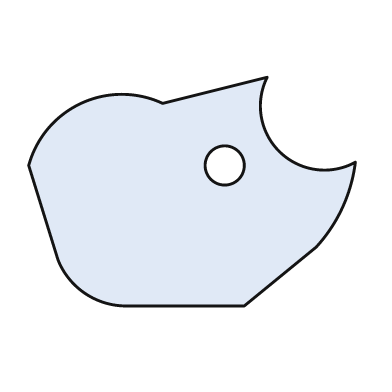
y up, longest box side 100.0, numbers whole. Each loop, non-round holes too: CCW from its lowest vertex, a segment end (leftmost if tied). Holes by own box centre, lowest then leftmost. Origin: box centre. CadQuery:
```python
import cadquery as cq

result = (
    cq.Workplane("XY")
    .moveTo(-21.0, -35.0)
    .lineTo(16.0, -35.0)
    .lineTo(38.0, -17.0)
    .threePointArc((46.0, -5.0), (50.0, 9.0))
    .threePointArc((27.0, 12.0), (23.0, 35.0))
    .lineTo(-9.0, 27.0)
    .threePointArc((-34.0, 27.0), (-50.0, 8.0))
    .lineTo(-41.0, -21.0)
    .threePointArc((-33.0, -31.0), (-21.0, -35.0))
    .close()
    .moveTo(10.0, 8.0)
    .circle(6.0)
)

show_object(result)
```